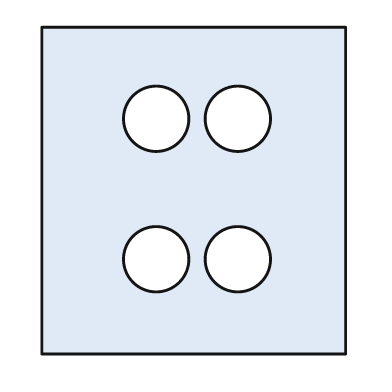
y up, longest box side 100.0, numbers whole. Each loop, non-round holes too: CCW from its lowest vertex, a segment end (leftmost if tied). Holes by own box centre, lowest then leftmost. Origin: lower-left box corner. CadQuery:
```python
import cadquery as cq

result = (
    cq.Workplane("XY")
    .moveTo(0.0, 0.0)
    .lineTo(93.0, 0.0)
    .lineTo(93.0, 100.0)
    .lineTo(0.0, 100.0)
    .close()
    .moveTo(35.0, 29.0)
    .circle(10.0)
    .moveTo(60.0, 29.0)
    .circle(10.0)
    .moveTo(35.0, 72.0)
    .circle(10.0)
    .moveTo(60.0, 72.0)
    .circle(10.0)
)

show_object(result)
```